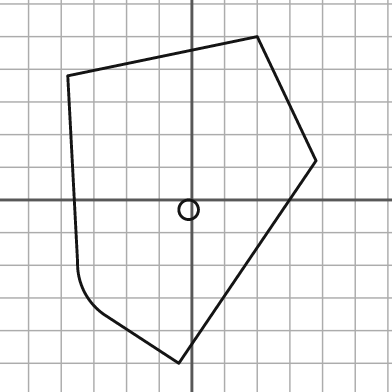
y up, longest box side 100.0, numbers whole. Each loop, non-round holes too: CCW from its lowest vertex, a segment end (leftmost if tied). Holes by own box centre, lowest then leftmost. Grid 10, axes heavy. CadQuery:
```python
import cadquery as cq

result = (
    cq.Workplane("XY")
    .moveTo(-4.0, -50.0)
    .lineTo(38.0, 12.0)
    .lineTo(20.0, 50.0)
    .lineTo(-38.0, 38.0)
    .lineTo(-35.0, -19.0)
    .threePointArc((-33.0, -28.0), (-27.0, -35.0))
    .close()
    .moveTo(-1.0, -3.0)
    .circle(3.0)
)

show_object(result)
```